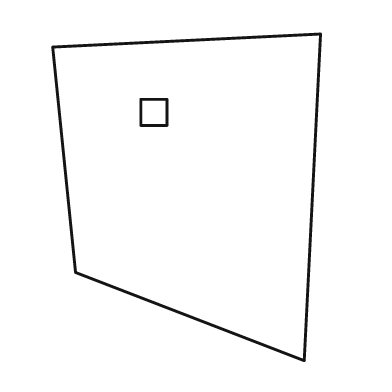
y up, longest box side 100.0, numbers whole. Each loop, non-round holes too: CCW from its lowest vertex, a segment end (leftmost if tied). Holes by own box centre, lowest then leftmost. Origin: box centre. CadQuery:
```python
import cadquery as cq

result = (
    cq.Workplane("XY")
    .moveTo(36.0, -50.0)
    .lineTo(41.0, 50.0)
    .lineTo(-41.0, 46.0)
    .lineTo(-34.0, -23.0)
    .close()
    .moveTo(-14.0, 22.0)
    .lineTo(-6.0, 22.0)
    .lineTo(-6.0, 30.0)
    .lineTo(-14.0, 30.0)
    .close()
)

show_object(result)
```